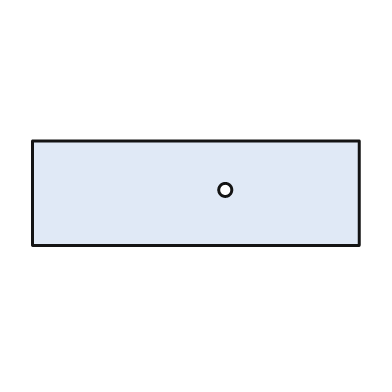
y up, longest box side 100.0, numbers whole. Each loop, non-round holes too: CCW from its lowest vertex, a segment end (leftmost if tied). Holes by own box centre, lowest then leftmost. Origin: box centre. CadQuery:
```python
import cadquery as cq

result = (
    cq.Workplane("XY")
    .moveTo(-50.0, -16.0)
    .lineTo(50.0, -16.0)
    .lineTo(50.0, 16.0)
    .lineTo(-50.0, 16.0)
    .close()
    .moveTo(9.0, 1.0)
    .circle(2.0)
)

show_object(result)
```